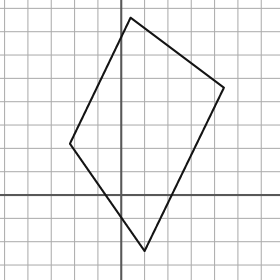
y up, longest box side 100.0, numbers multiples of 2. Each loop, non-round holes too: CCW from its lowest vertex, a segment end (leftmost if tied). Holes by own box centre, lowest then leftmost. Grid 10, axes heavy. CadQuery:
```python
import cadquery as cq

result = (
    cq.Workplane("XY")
    .moveTo(10.0, -24.0)
    .lineTo(44.0, 46.0)
    .lineTo(4.0, 76.0)
    .lineTo(-22.0, 22.0)
    .close()
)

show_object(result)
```